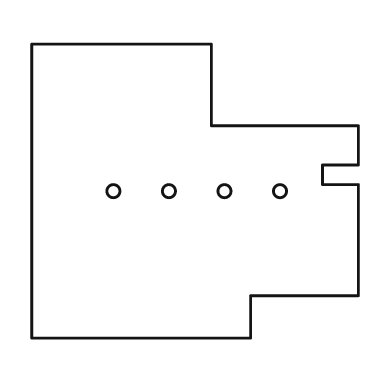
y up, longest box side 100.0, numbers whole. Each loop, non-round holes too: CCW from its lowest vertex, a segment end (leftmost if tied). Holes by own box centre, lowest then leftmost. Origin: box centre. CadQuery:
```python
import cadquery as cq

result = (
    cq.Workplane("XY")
    .moveTo(-50.0, -45.0)
    .lineTo(17.0, -45.0)
    .lineTo(17.0, -32.0)
    .lineTo(50.0, -32.0)
    .lineTo(50.0, 2.0)
    .lineTo(39.0, 2.0)
    .lineTo(39.0, 8.0)
    .lineTo(50.0, 8.0)
    .lineTo(50.0, 20.0)
    .lineTo(5.0, 20.0)
    .lineTo(5.0, 45.0)
    .lineTo(-50.0, 45.0)
    .close()
    .moveTo(-25.0, 0.0)
    .circle(2.0)
    .moveTo(-8.0, 0.0)
    .circle(2.0)
    .moveTo(9.0, 0.0)
    .circle(2.0)
    .moveTo(26.0, 0.0)
    .circle(2.0)
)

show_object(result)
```